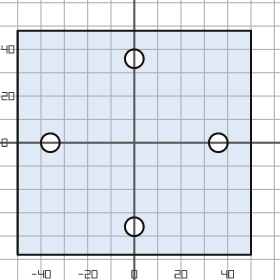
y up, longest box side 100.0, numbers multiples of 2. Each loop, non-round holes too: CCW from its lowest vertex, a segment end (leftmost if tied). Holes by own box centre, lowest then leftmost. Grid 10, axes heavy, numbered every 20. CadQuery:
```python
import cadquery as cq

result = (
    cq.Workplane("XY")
    .moveTo(-50.0, -48.0)
    .lineTo(50.0, -48.0)
    .lineTo(50.0, 48.0)
    .lineTo(-50.0, 48.0)
    .close()
    .moveTo(0.0, -36.0)
    .circle(4.0)
    .moveTo(-36.0, 0.0)
    .circle(4.0)
    .moveTo(36.0, 0.0)
    .circle(4.0)
    .moveTo(0.0, 36.0)
    .circle(4.0)
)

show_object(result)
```